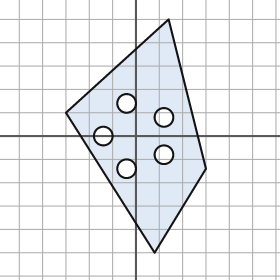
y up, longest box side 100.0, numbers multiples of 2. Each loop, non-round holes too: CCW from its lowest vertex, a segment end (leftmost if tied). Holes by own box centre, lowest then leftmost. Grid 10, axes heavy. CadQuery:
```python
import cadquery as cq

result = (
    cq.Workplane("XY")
    .moveTo(8.0, -50.0)
    .lineTo(30.0, -14.0)
    .lineTo(14.0, 50.0)
    .lineTo(-30.0, 10.0)
    .close()
    .moveTo(-4.0, -14.0)
    .circle(4.0)
    .moveTo(12.0, -8.0)
    .circle(4.0)
    .moveTo(-14.0, 0.0)
    .circle(4.0)
    .moveTo(12.0, 8.0)
    .circle(4.0)
    .moveTo(-4.0, 14.0)
    .circle(4.0)
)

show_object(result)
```